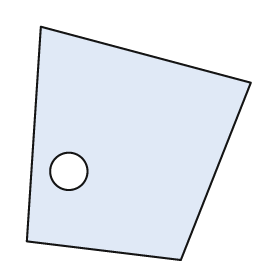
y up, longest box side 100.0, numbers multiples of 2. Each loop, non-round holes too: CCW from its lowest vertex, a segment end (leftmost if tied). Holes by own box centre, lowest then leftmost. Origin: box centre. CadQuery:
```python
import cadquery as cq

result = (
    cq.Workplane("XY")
    .moveTo(18.0, -50.0)
    .lineTo(48.0, 26.0)
    .lineTo(-42.0, 50.0)
    .lineTo(-48.0, -42.0)
    .close()
    .moveTo(-30.0, -12.0)
    .circle(8.0)
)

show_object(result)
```